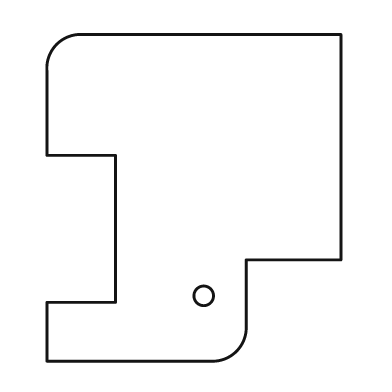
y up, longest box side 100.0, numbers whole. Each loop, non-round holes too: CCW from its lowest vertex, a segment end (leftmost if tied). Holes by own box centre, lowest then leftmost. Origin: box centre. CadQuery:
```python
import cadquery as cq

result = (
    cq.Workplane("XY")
    .moveTo(-45.0, -50.0)
    .lineTo(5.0, -50.0)
    .threePointArc((13.0, -47.0), (16.0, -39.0))
    .lineTo(16.0, -19.0)
    .lineTo(45.0, -19.0)
    .lineTo(45.0, 50.0)
    .lineTo(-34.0, 50.0)
    .threePointArc((-42.0, 47.0), (-45.0, 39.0))
    .lineTo(-45.0, 13.0)
    .lineTo(-24.0, 13.0)
    .lineTo(-24.0, -32.0)
    .lineTo(-45.0, -32.0)
    .close()
    .moveTo(3.0, -30.0)
    .circle(3.0)
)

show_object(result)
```